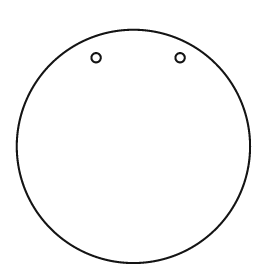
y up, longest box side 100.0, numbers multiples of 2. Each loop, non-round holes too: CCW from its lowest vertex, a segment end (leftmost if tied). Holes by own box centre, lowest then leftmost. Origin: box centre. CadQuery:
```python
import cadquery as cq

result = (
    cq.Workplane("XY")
    .moveTo(0.0, 0.0)
    .circle(50.0)
    .moveTo(-16.0, 38.0)
    .circle(2.0)
    .moveTo(20.0, 38.0)
    .circle(2.0)
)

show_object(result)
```